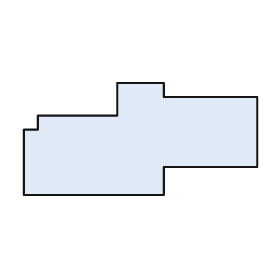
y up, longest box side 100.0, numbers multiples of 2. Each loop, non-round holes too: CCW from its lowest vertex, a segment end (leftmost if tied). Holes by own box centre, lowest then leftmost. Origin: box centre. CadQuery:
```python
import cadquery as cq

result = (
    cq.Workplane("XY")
    .moveTo(-50.0, -24.0)
    .lineTo(10.0, -24.0)
    .lineTo(10.0, -12.0)
    .lineTo(50.0, -12.0)
    .lineTo(50.0, 18.0)
    .lineTo(10.0, 18.0)
    .lineTo(10.0, 24.0)
    .lineTo(-10.0, 24.0)
    .lineTo(-10.0, 10.0)
    .lineTo(-44.0, 10.0)
    .lineTo(-44.0, 4.0)
    .lineTo(-50.0, 4.0)
    .close()
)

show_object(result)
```